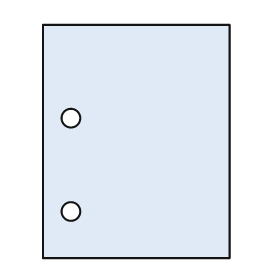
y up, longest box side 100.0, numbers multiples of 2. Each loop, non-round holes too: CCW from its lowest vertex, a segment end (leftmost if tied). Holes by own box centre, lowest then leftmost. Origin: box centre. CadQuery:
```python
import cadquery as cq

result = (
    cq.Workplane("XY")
    .moveTo(-40.0, -50.0)
    .lineTo(40.0, -50.0)
    .lineTo(40.0, 50.0)
    .lineTo(-40.0, 50.0)
    .close()
    .moveTo(-28.0, -30.0)
    .circle(4.0)
    .moveTo(-28.0, 10.0)
    .circle(4.0)
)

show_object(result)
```